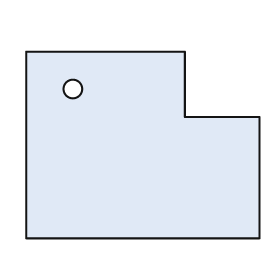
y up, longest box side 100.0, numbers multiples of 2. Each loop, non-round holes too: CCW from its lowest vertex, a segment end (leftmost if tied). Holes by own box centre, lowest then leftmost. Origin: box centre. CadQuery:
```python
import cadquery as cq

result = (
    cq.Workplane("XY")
    .moveTo(-50.0, -40.0)
    .lineTo(50.0, -40.0)
    .lineTo(50.0, 12.0)
    .lineTo(18.0, 12.0)
    .lineTo(18.0, 40.0)
    .lineTo(-50.0, 40.0)
    .close()
    .moveTo(-30.0, 24.0)
    .circle(4.0)
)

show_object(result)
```